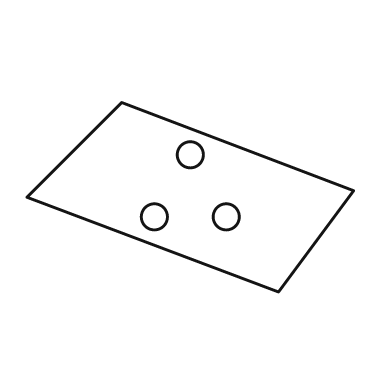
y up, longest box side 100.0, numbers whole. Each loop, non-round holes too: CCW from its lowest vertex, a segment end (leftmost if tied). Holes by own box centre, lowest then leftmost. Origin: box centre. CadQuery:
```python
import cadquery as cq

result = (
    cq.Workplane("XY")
    .moveTo(27.0, -29.0)
    .lineTo(50.0, 2.0)
    .lineTo(-21.0, 29.0)
    .lineTo(-50.0, 0.0)
    .close()
    .moveTo(-11.0, -6.0)
    .circle(4.0)
    .moveTo(11.0, -6.0)
    .circle(4.0)
    .moveTo(0.0, 13.0)
    .circle(4.0)
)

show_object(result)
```